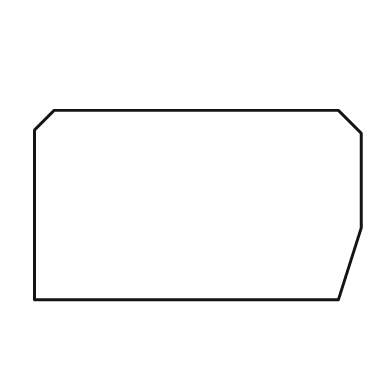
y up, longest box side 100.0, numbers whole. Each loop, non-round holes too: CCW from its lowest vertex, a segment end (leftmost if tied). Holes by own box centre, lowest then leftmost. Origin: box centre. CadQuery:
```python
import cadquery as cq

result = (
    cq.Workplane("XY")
    .moveTo(-50.0, -29.0)
    .lineTo(43.0, -29.0)
    .lineTo(50.0, -7.0)
    .lineTo(50.0, 22.0)
    .lineTo(43.0, 29.0)
    .lineTo(-44.0, 29.0)
    .lineTo(-50.0, 23.0)
    .close()
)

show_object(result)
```